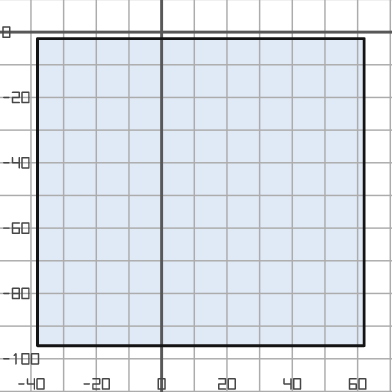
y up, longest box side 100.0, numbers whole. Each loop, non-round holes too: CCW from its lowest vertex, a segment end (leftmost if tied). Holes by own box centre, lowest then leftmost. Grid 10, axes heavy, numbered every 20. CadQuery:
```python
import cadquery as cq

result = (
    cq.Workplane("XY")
    .moveTo(-38.0, -96.0)
    .lineTo(62.0, -96.0)
    .lineTo(62.0, -2.0)
    .lineTo(-38.0, -2.0)
    .close()
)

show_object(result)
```